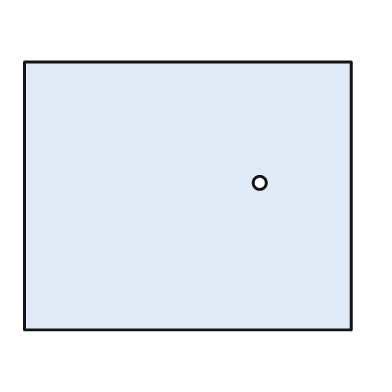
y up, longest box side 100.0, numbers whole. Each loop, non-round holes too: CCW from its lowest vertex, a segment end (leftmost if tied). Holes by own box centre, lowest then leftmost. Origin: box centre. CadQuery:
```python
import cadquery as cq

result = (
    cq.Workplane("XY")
    .moveTo(-50.0, -41.0)
    .lineTo(50.0, -41.0)
    .lineTo(50.0, 41.0)
    .lineTo(-50.0, 41.0)
    .close()
    .moveTo(22.0, 4.0)
    .circle(2.0)
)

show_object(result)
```